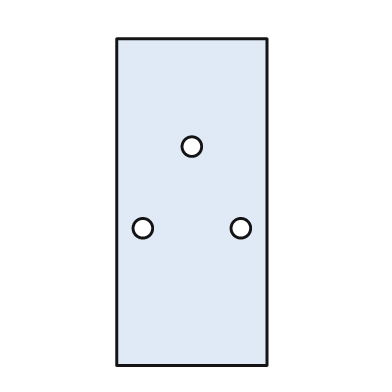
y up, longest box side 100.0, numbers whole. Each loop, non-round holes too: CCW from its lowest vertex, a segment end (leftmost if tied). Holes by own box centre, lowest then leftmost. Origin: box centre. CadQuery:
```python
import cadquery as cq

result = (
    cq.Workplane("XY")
    .moveTo(-23.0, -50.0)
    .lineTo(23.0, -50.0)
    .lineTo(23.0, 50.0)
    .lineTo(-23.0, 50.0)
    .close()
    .moveTo(-15.0, -8.0)
    .circle(3.0)
    .moveTo(15.0, -8.0)
    .circle(3.0)
    .moveTo(0.0, 17.0)
    .circle(3.0)
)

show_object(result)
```